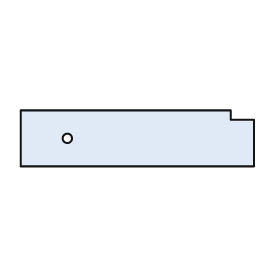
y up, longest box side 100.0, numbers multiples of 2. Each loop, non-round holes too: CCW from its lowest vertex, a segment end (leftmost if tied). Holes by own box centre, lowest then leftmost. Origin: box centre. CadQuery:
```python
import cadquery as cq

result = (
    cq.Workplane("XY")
    .moveTo(-50.0, -12.0)
    .lineTo(50.0, -12.0)
    .lineTo(50.0, 8.0)
    .lineTo(40.0, 8.0)
    .lineTo(40.0, 12.0)
    .lineTo(-50.0, 12.0)
    .close()
    .moveTo(-30.0, 0.0)
    .circle(2.0)
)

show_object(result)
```